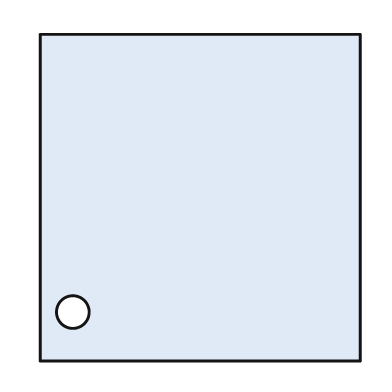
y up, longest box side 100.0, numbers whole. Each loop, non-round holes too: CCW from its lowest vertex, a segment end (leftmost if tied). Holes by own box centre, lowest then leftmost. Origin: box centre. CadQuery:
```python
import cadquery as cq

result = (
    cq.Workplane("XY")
    .moveTo(-49.0, -50.0)
    .lineTo(49.0, -50.0)
    .lineTo(49.0, 50.0)
    .lineTo(-49.0, 50.0)
    .close()
    .moveTo(-39.0, -35.0)
    .circle(5.0)
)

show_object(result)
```